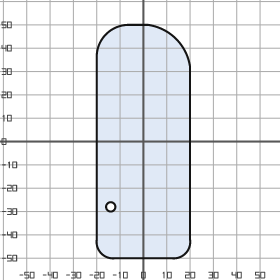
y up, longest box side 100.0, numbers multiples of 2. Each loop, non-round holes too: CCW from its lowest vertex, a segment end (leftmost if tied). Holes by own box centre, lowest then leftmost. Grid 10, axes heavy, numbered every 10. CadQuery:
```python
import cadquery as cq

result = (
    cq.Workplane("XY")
    .moveTo(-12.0, -50.0)
    .lineTo(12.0, -50.0)
    .threePointArc((18.0, -48.0), (20.0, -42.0))
    .lineTo(20.0, 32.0)
    .threePointArc((14.0, 44.0), (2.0, 50.0))
    .lineTo(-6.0, 50.0)
    .threePointArc((-16.0, 46.0), (-20.0, 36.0))
    .lineTo(-20.0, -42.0)
    .threePointArc((-18.0, -48.0), (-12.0, -50.0))
    .close()
    .moveTo(-14.0, -28.0)
    .circle(2.0)
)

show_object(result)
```